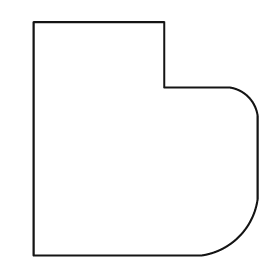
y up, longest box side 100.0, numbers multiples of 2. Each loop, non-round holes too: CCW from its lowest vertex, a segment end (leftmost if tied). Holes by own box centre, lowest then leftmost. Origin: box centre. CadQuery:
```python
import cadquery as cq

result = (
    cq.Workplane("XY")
    .moveTo(-48.0, -50.0)
    .lineTo(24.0, -50.0)
    .threePointArc((40.0, -42.0), (48.0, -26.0))
    .lineTo(48.0, 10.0)
    .threePointArc((44.0, 18.0), (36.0, 22.0))
    .lineTo(8.0, 22.0)
    .lineTo(8.0, 50.0)
    .lineTo(-48.0, 50.0)
    .close()
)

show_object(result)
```